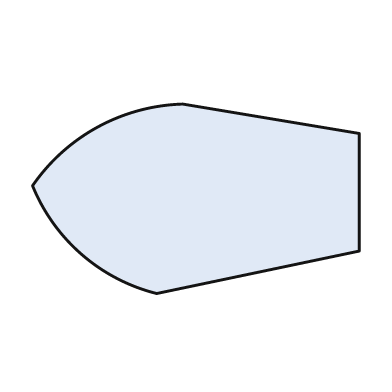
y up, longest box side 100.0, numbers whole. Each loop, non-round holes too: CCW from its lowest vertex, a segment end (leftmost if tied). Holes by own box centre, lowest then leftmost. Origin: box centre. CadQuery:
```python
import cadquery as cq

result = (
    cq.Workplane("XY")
    .moveTo(-12.0, -29.0)
    .lineTo(50.0, -16.0)
    .lineTo(50.0, 20.0)
    .lineTo(-4.0, 29.0)
    .threePointArc((-30.0, 22.0), (-50.0, 4.0))
    .threePointArc((-35.0, -17.0), (-12.0, -29.0))
    .close()
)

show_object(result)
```